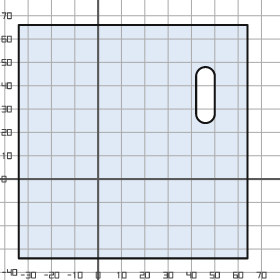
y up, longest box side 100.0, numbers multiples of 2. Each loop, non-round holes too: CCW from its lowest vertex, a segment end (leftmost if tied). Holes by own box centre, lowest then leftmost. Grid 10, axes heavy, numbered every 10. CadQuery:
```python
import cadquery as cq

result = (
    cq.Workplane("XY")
    .moveTo(-34.0, -34.0)
    .lineTo(64.0, -34.0)
    .lineTo(64.0, 66.0)
    .lineTo(-34.0, 66.0)
    .close()
    .moveTo(42.0, 28.0)
    .threePointArc((46.0, 24.0), (50.0, 28.0))
    .lineTo(50.0, 44.0)
    .threePointArc((46.0, 48.0), (42.0, 44.0))
    .close()
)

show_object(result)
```